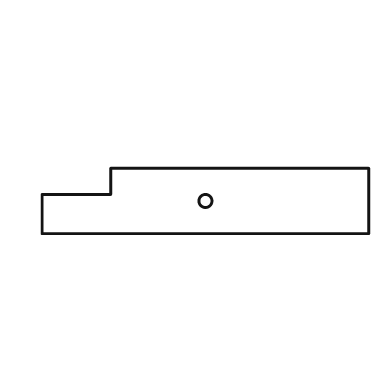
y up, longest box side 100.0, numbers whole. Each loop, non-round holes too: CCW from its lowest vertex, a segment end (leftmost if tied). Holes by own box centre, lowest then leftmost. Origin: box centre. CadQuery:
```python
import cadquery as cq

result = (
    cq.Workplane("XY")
    .moveTo(-50.0, -10.0)
    .lineTo(50.0, -10.0)
    .lineTo(50.0, 10.0)
    .lineTo(-29.0, 10.0)
    .lineTo(-29.0, 2.0)
    .lineTo(-50.0, 2.0)
    .close()
    .moveTo(0.0, 0.0)
    .circle(2.0)
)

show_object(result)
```